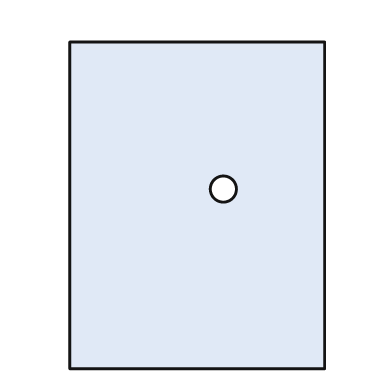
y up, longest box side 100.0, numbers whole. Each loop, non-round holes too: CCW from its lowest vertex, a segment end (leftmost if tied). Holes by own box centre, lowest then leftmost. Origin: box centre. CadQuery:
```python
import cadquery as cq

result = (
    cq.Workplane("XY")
    .moveTo(-39.0, -50.0)
    .lineTo(39.0, -50.0)
    .lineTo(39.0, 50.0)
    .lineTo(-39.0, 50.0)
    .close()
    .moveTo(8.0, 5.0)
    .circle(4.0)
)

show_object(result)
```